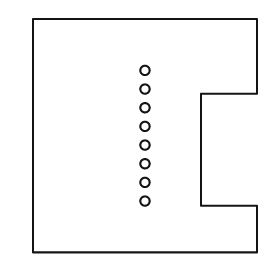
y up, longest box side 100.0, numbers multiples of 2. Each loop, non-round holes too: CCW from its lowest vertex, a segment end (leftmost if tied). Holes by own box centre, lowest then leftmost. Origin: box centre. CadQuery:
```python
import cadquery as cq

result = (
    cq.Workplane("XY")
    .moveTo(-48.0, -50.0)
    .lineTo(48.0, -50.0)
    .lineTo(48.0, -30.0)
    .lineTo(24.0, -30.0)
    .lineTo(24.0, 18.0)
    .lineTo(48.0, 18.0)
    .lineTo(48.0, 50.0)
    .lineTo(-48.0, 50.0)
    .close()
    .moveTo(0.0, -28.0)
    .circle(2.0)
    .moveTo(0.0, -20.0)
    .circle(2.0)
    .moveTo(0.0, -12.0)
    .circle(2.0)
    .moveTo(0.0, -4.0)
    .circle(2.0)
    .moveTo(0.0, 4.0)
    .circle(2.0)
    .moveTo(0.0, 12.0)
    .circle(2.0)
    .moveTo(0.0, 20.0)
    .circle(2.0)
    .moveTo(0.0, 28.0)
    .circle(2.0)
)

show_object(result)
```